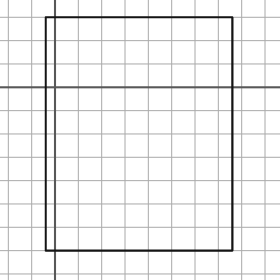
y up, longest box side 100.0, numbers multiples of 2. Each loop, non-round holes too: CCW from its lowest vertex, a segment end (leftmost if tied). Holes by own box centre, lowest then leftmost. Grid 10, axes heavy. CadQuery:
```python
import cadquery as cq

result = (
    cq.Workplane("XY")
    .moveTo(-4.0, -70.0)
    .lineTo(76.0, -70.0)
    .lineTo(76.0, 30.0)
    .lineTo(-4.0, 30.0)
    .close()
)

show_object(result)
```